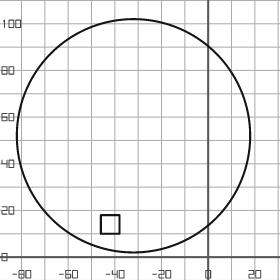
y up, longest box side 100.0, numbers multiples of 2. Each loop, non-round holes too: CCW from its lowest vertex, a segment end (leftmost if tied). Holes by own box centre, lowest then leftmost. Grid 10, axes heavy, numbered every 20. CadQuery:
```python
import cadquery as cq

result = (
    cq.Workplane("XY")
    .moveTo(-32.0, 52.0)
    .circle(50.0)
    .moveTo(-46.0, 10.0)
    .lineTo(-38.0, 10.0)
    .lineTo(-38.0, 18.0)
    .lineTo(-46.0, 18.0)
    .close()
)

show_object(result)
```